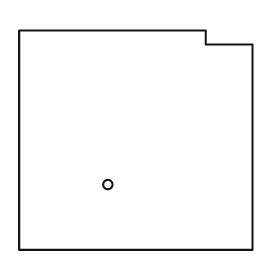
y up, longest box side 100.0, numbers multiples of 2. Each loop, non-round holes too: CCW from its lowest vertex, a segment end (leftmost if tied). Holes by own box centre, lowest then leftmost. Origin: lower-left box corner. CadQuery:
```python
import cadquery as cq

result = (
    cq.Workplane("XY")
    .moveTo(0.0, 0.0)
    .lineTo(100.0, 0.0)
    .lineTo(100.0, 88.0)
    .lineTo(80.0, 88.0)
    .lineTo(80.0, 94.0)
    .lineTo(0.0, 94.0)
    .close()
    .moveTo(38.0, 28.0)
    .circle(2.0)
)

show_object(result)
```